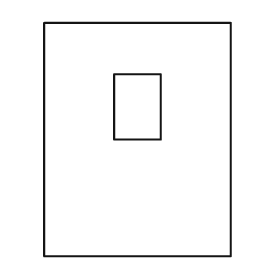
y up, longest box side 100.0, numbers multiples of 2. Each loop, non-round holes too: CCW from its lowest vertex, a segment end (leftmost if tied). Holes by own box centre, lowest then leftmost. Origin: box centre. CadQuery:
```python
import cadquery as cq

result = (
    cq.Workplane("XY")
    .moveTo(-40.0, -50.0)
    .lineTo(40.0, -50.0)
    .lineTo(40.0, 50.0)
    .lineTo(-40.0, 50.0)
    .close()
    .moveTo(-10.0, 0.0)
    .lineTo(10.0, 0.0)
    .lineTo(10.0, 28.0)
    .lineTo(-10.0, 28.0)
    .close()
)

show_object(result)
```